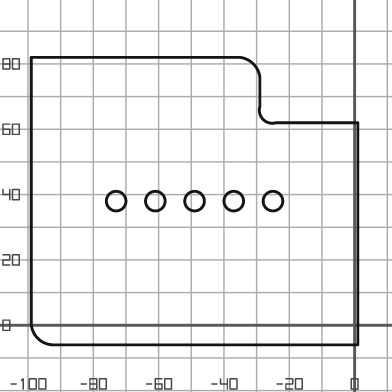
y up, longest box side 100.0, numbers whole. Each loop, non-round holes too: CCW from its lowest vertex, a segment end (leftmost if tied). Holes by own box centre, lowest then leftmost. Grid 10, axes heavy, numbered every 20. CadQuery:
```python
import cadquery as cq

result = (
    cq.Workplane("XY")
    .moveTo(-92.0, -6.0)
    .lineTo(1.0, -6.0)
    .lineTo(1.0, 62.0)
    .lineTo(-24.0, 62.0)
    .threePointArc((-28.0, 63.0), (-29.0, 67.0))
    .lineTo(-29.0, 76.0)
    .threePointArc((-31.0, 80.0), (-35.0, 82.0))
    .lineTo(-99.0, 82.0)
    .lineTo(-99.0, 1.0)
    .threePointArc((-97.0, -4.0), (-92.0, -6.0))
    .close()
    .moveTo(-73.0, 38.0)
    .circle(3.0)
    .moveTo(-61.0, 38.0)
    .circle(3.0)
    .moveTo(-49.0, 38.0)
    .circle(3.0)
    .moveTo(-37.0, 38.0)
    .circle(3.0)
    .moveTo(-25.0, 38.0)
    .circle(3.0)
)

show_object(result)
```